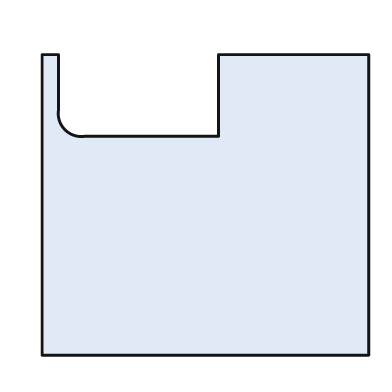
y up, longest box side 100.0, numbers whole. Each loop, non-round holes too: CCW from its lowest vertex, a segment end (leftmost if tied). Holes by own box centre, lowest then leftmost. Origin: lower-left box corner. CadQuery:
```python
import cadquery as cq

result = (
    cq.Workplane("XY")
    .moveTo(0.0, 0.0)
    .lineTo(100.0, 0.0)
    .lineTo(100.0, 92.0)
    .lineTo(54.0, 92.0)
    .lineTo(54.0, 67.0)
    .lineTo(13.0, 67.0)
    .threePointArc((7.0, 69.0), (5.0, 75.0))
    .lineTo(5.0, 92.0)
    .lineTo(0.0, 92.0)
    .close()
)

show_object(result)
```